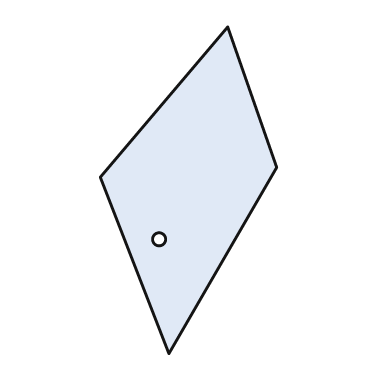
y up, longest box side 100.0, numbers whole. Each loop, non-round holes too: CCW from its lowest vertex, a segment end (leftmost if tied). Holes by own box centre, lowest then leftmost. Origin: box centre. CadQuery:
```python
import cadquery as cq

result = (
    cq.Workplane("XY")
    .moveTo(-6.0, -50.0)
    .lineTo(27.0, 7.0)
    .lineTo(12.0, 50.0)
    .lineTo(-27.0, 4.0)
    .close()
    .moveTo(-9.0, -15.0)
    .circle(2.0)
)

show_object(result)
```